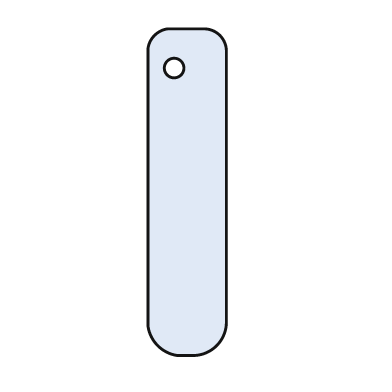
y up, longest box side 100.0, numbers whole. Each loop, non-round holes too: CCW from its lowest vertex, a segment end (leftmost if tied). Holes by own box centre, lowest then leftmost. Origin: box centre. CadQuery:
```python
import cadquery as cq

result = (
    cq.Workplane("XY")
    .moveTo(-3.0, -50.0)
    .lineTo(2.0, -50.0)
    .threePointArc((9.0, -47.0), (12.0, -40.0))
    .lineTo(12.0, 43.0)
    .threePointArc((10.0, 48.0), (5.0, 50.0))
    .lineTo(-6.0, 50.0)
    .threePointArc((-10.0, 48.0), (-12.0, 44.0))
    .lineTo(-12.0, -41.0)
    .threePointArc((-9.0, -47.0), (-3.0, -50.0))
    .close()
    .moveTo(-4.0, 38.0)
    .circle(3.0)
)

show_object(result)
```